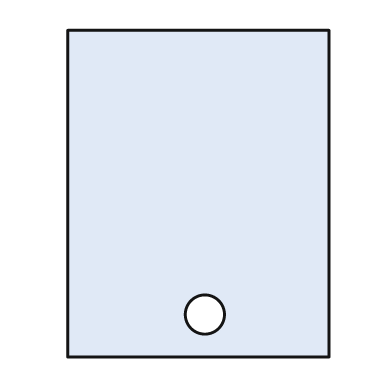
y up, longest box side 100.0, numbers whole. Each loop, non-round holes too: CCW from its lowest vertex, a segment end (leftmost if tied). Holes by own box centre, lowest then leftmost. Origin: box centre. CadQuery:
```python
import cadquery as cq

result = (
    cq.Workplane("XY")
    .moveTo(-40.0, -50.0)
    .lineTo(40.0, -50.0)
    .lineTo(40.0, 50.0)
    .lineTo(-40.0, 50.0)
    .close()
    .moveTo(2.0, -37.0)
    .circle(6.0)
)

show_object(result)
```